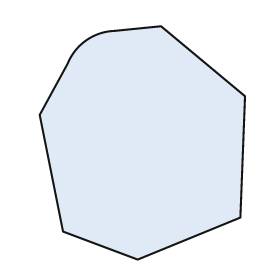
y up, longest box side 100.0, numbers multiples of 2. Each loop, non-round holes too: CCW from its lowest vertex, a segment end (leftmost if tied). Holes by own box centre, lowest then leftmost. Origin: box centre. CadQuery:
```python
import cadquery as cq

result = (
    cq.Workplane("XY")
    .moveTo(-2.0, -50.0)
    .lineTo(42.0, -32.0)
    .lineTo(44.0, 20.0)
    .lineTo(8.0, 50.0)
    .lineTo(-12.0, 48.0)
    .threePointArc((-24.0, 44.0), (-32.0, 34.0))
    .lineTo(-44.0, 12.0)
    .lineTo(-34.0, -38.0)
    .close()
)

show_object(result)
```